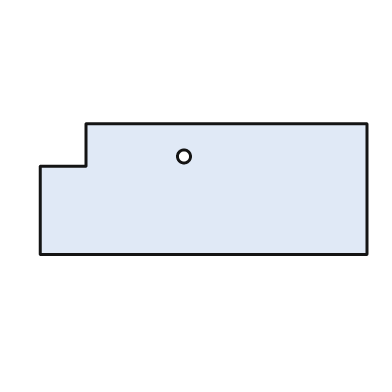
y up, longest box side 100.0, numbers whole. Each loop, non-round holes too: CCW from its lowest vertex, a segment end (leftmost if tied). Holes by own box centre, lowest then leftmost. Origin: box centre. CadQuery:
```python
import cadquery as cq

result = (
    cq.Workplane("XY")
    .moveTo(-50.0, -20.0)
    .lineTo(50.0, -20.0)
    .lineTo(50.0, 20.0)
    .lineTo(-36.0, 20.0)
    .lineTo(-36.0, 7.0)
    .lineTo(-50.0, 7.0)
    .close()
    .moveTo(-6.0, 10.0)
    .circle(2.0)
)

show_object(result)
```